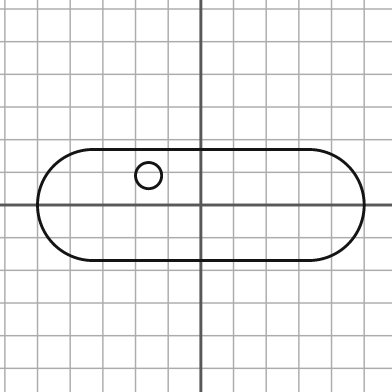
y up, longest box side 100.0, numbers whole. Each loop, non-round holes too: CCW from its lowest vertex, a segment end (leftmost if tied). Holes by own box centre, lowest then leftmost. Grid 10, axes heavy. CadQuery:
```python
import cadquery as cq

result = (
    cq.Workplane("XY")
    .moveTo(-33.0, -17.0)
    .lineTo(33.0, -17.0)
    .threePointArc((50.0, 0.0), (33.0, 17.0))
    .lineTo(-33.0, 17.0)
    .threePointArc((-50.0, 0.0), (-33.0, -17.0))
    .close()
    .moveTo(-16.0, 9.0)
    .circle(4.0)
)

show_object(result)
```